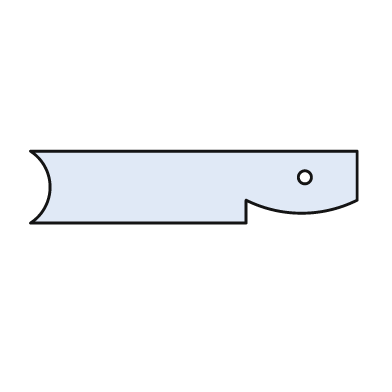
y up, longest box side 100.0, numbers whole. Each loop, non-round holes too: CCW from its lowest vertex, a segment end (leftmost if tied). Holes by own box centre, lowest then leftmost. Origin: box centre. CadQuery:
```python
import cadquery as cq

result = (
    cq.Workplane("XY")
    .moveTo(-50.0, -11.0)
    .lineTo(16.0, -11.0)
    .lineTo(16.0, -4.0)
    .threePointArc((33.0, -8.0), (50.0, -4.0))
    .lineTo(50.0, 11.0)
    .lineTo(-50.0, 11.0)
    .threePointArc((-44.0, 0.0), (-50.0, -11.0))
    .close()
    .moveTo(34.0, 3.0)
    .circle(2.0)
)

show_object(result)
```